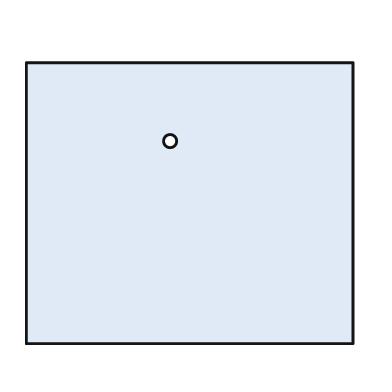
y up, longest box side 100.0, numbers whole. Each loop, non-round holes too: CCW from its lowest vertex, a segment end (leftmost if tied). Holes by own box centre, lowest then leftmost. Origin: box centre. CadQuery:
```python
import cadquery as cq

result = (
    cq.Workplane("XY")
    .moveTo(-50.0, -43.0)
    .lineTo(50.0, -43.0)
    .lineTo(50.0, 43.0)
    .lineTo(-50.0, 43.0)
    .close()
    .moveTo(-6.0, 19.0)
    .circle(2.0)
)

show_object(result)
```